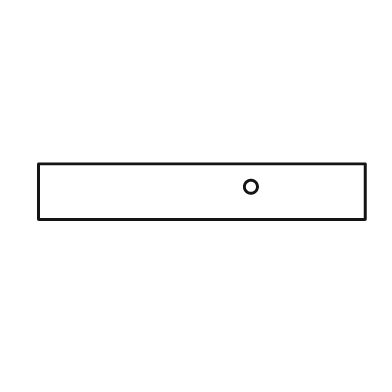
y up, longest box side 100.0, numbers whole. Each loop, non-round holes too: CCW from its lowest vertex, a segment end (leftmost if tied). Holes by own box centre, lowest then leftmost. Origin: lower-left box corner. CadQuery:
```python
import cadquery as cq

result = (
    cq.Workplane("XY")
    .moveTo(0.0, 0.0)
    .lineTo(100.0, 0.0)
    .lineTo(100.0, 17.0)
    .lineTo(0.0, 17.0)
    .close()
    .moveTo(65.0, 10.0)
    .circle(2.0)
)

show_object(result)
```